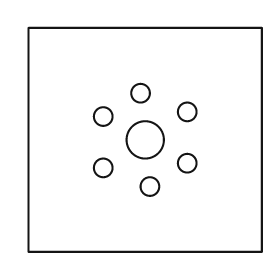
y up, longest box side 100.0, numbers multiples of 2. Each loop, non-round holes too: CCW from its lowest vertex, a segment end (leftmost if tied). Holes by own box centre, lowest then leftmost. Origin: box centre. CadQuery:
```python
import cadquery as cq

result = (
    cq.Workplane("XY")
    .moveTo(-50.0, -48.0)
    .lineTo(50.0, -48.0)
    .lineTo(50.0, 48.0)
    .lineTo(-50.0, 48.0)
    .close()
    .moveTo(2.0, -20.0)
    .circle(4.0)
    .moveTo(-18.0, -12.0)
    .circle(4.0)
    .moveTo(18.0, -10.0)
    .circle(4.0)
    .moveTo(0.0, 0.0)
    .circle(8.0)
    .moveTo(-18.0, 10.0)
    .circle(4.0)
    .moveTo(18.0, 12.0)
    .circle(4.0)
    .moveTo(-2.0, 20.0)
    .circle(4.0)
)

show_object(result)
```